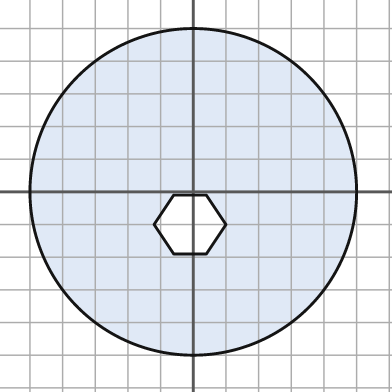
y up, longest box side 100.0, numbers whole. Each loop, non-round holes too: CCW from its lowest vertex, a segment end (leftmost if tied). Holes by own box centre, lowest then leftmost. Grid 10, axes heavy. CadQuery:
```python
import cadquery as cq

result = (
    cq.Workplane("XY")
    .moveTo(0.0, 0.0)
    .circle(50.0)
    .moveTo(-6.0, -19.0)
    .lineTo(4.0, -19.0)
    .lineTo(10.0, -10.0)
    .lineTo(4.0, -1.0)
    .lineTo(-6.0, -1.0)
    .lineTo(-12.0, -10.0)
    .close()
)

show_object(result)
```